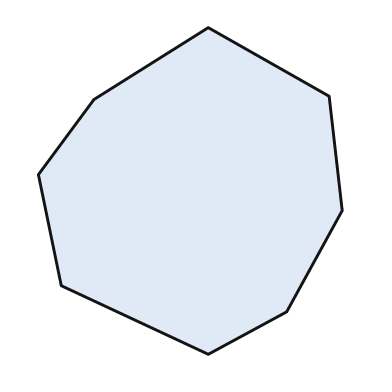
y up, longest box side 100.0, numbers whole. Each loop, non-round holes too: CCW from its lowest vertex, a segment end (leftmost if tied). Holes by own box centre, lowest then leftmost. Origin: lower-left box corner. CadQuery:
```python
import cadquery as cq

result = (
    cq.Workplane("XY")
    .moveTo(52.0, 0.0)
    .lineTo(76.0, 13.0)
    .lineTo(93.0, 44.0)
    .lineTo(89.0, 79.0)
    .lineTo(52.0, 100.0)
    .lineTo(17.0, 78.0)
    .lineTo(0.0, 55.0)
    .lineTo(7.0, 21.0)
    .close()
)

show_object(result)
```